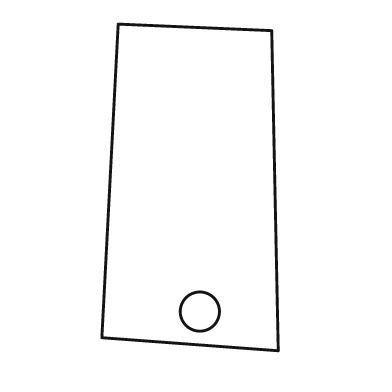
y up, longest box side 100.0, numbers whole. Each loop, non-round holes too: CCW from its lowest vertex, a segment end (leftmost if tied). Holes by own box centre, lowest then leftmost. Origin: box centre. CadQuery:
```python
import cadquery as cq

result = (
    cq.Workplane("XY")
    .moveTo(27.0, -50.0)
    .lineTo(25.0, 48.0)
    .lineTo(-22.0, 50.0)
    .lineTo(-27.0, -46.0)
    .close()
    .moveTo(3.0, -38.0)
    .circle(6.0)
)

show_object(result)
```